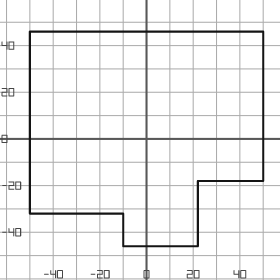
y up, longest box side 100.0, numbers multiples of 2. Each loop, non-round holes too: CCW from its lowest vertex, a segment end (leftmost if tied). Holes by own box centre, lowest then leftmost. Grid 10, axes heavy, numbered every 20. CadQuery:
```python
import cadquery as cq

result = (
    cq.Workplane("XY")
    .moveTo(-10.0, -46.0)
    .lineTo(22.0, -46.0)
    .lineTo(22.0, -18.0)
    .lineTo(50.0, -18.0)
    .lineTo(50.0, 46.0)
    .lineTo(-50.0, 46.0)
    .lineTo(-50.0, -32.0)
    .lineTo(-10.0, -32.0)
    .close()
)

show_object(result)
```